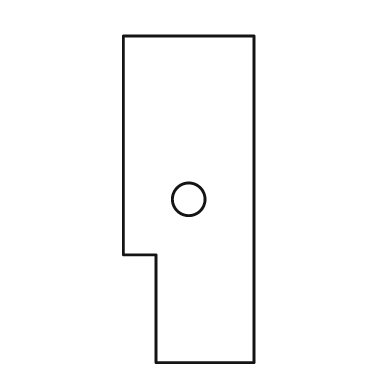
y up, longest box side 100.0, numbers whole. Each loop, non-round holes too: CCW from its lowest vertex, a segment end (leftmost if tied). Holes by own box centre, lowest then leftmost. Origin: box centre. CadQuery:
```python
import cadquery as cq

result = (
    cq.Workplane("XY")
    .moveTo(-10.0, -50.0)
    .lineTo(20.0, -50.0)
    .lineTo(20.0, 50.0)
    .lineTo(-20.0, 50.0)
    .lineTo(-20.0, -17.0)
    .lineTo(-10.0, -17.0)
    .close()
    .moveTo(0.0, 0.0)
    .circle(5.0)
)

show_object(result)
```